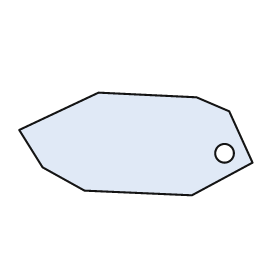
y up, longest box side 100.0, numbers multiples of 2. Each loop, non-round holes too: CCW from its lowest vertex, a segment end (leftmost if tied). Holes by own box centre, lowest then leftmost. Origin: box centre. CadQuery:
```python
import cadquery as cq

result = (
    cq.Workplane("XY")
    .moveTo(24.0, -22.0)
    .lineTo(50.0, -8.0)
    .lineTo(40.0, 14.0)
    .lineTo(26.0, 20.0)
    .lineTo(-16.0, 22.0)
    .lineTo(-50.0, 6.0)
    .lineTo(-40.0, -10.0)
    .lineTo(-22.0, -20.0)
    .close()
    .moveTo(38.0, -4.0)
    .circle(4.0)
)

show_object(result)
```